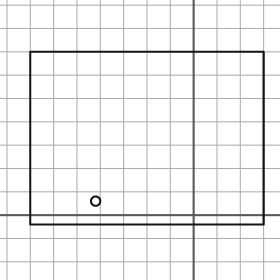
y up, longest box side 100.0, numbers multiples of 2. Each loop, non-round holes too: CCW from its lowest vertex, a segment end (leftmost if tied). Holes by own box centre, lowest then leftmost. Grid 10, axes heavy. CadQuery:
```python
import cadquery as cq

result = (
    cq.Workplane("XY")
    .moveTo(-70.0, -4.0)
    .lineTo(30.0, -4.0)
    .lineTo(30.0, 70.0)
    .lineTo(-70.0, 70.0)
    .close()
    .moveTo(-42.0, 6.0)
    .circle(2.0)
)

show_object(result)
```